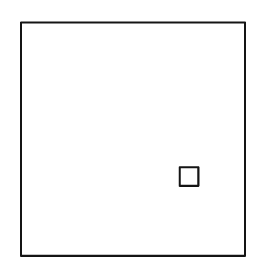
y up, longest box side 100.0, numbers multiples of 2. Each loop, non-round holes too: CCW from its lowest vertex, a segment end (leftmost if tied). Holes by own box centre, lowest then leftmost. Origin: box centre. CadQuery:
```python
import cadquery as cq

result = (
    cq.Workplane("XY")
    .moveTo(-48.0, -50.0)
    .lineTo(48.0, -50.0)
    .lineTo(48.0, 50.0)
    .lineTo(-48.0, 50.0)
    .close()
    .moveTo(20.0, -20.0)
    .lineTo(28.0, -20.0)
    .lineTo(28.0, -12.0)
    .lineTo(20.0, -12.0)
    .close()
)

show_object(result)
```